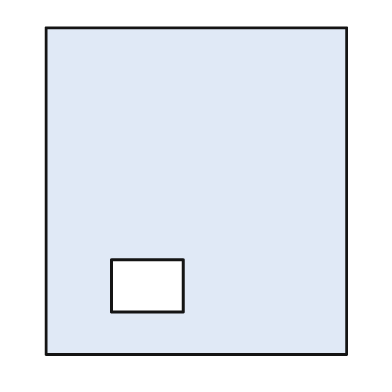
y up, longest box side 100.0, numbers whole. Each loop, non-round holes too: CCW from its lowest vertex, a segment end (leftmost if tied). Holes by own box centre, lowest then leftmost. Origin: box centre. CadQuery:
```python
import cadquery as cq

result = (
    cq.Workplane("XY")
    .moveTo(-46.0, -50.0)
    .lineTo(46.0, -50.0)
    .lineTo(46.0, 50.0)
    .lineTo(-46.0, 50.0)
    .close()
    .moveTo(-26.0, -37.0)
    .lineTo(-4.0, -37.0)
    .lineTo(-4.0, -21.0)
    .lineTo(-26.0, -21.0)
    .close()
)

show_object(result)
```